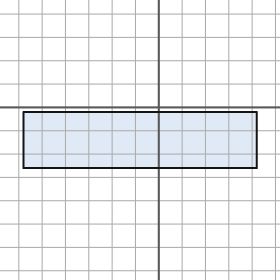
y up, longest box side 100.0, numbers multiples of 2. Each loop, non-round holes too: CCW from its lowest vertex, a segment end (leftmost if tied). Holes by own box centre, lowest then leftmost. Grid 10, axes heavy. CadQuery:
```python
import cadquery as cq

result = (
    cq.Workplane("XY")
    .moveTo(-58.0, -26.0)
    .lineTo(42.0, -26.0)
    .lineTo(42.0, -2.0)
    .lineTo(-58.0, -2.0)
    .close()
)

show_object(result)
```